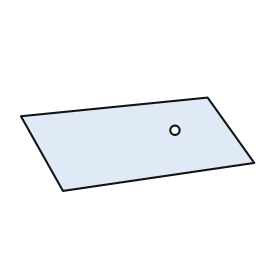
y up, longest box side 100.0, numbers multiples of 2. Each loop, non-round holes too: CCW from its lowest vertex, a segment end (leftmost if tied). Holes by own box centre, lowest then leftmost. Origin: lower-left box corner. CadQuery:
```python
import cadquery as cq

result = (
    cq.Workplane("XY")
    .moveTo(18.0, 0.0)
    .lineTo(100.0, 12.0)
    .lineTo(80.0, 40.0)
    .lineTo(0.0, 32.0)
    .close()
    .moveTo(66.0, 26.0)
    .circle(2.0)
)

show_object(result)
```